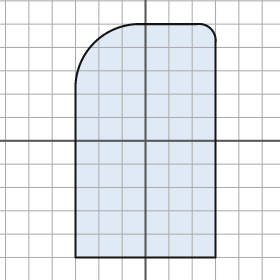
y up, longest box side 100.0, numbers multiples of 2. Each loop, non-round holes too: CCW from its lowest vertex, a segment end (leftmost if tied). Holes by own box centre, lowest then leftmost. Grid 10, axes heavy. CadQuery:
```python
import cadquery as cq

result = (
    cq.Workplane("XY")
    .moveTo(-30.0, -50.0)
    .lineTo(30.0, -50.0)
    .lineTo(30.0, 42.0)
    .threePointArc((28.0, 48.0), (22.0, 50.0))
    .lineTo(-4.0, 50.0)
    .threePointArc((-22.0, 42.0), (-30.0, 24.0))
    .close()
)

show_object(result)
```